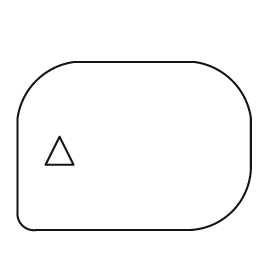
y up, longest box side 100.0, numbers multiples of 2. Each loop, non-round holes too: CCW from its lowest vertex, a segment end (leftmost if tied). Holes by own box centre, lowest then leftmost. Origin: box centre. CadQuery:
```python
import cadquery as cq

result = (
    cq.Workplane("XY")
    .moveTo(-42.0, -36.0)
    .lineTo(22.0, -36.0)
    .threePointArc((42.0, -28.0), (50.0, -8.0))
    .lineTo(50.0, 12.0)
    .threePointArc((42.0, 28.0), (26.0, 36.0))
    .lineTo(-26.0, 36.0)
    .threePointArc((-42.0, 28.0), (-50.0, 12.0))
    .lineTo(-50.0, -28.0)
    .threePointArc((-48.0, -34.0), (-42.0, -36.0))
    .close()
    .moveTo(-38.0, -8.0)
    .lineTo(-26.0, -8.0)
    .lineTo(-32.0, 4.0)
    .close()
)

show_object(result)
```